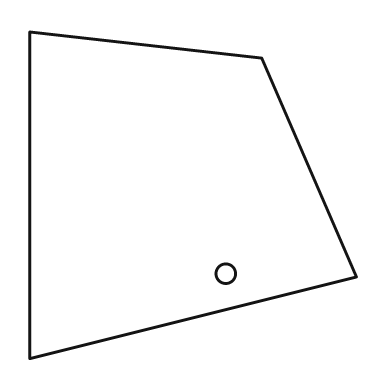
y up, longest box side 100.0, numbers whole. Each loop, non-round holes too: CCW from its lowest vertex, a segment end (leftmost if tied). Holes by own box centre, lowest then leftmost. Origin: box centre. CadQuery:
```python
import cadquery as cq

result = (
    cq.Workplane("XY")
    .moveTo(-50.0, -50.0)
    .lineTo(50.0, -25.0)
    .lineTo(21.0, 42.0)
    .lineTo(-50.0, 50.0)
    .close()
    .moveTo(10.0, -24.0)
    .circle(3.0)
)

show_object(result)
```